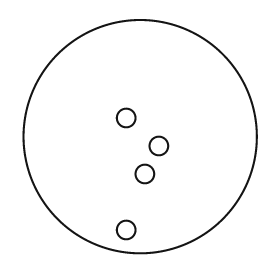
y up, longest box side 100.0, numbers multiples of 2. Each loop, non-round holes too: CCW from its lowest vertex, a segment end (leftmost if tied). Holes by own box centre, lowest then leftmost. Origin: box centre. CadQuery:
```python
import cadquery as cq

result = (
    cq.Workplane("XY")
    .moveTo(0.0, 0.0)
    .circle(50.0)
    .moveTo(-6.0, -40.0)
    .circle(4.0)
    .moveTo(2.0, -16.0)
    .circle(4.0)
    .moveTo(8.0, -4.0)
    .circle(4.0)
    .moveTo(-6.0, 8.0)
    .circle(4.0)
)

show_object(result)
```